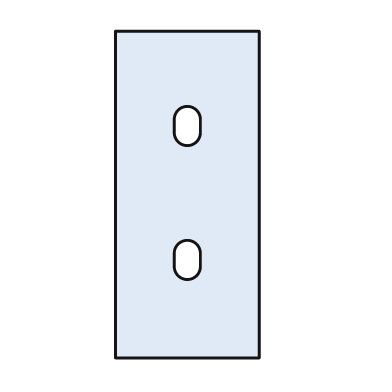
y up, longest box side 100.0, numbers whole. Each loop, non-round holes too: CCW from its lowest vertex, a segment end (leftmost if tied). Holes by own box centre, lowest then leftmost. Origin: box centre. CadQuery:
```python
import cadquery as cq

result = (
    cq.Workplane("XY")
    .moveTo(-22.0, -50.0)
    .lineTo(22.0, -50.0)
    .lineTo(22.0, 50.0)
    .lineTo(-22.0, 50.0)
    .close()
    .moveTo(-4.0, -22.0)
    .threePointArc((0.0, -26.0), (4.0, -22.0))
    .lineTo(4.0, -18.0)
    .threePointArc((0.0, -14.0), (-4.0, -18.0))
    .close()
    .moveTo(-4.0, 19.0)
    .threePointArc((0.0, 15.0), (4.0, 19.0))
    .lineTo(4.0, 23.0)
    .threePointArc((0.0, 27.0), (-4.0, 23.0))
    .close()
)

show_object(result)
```